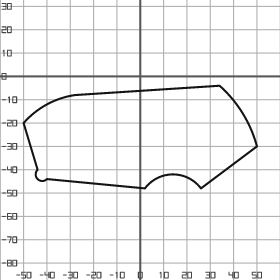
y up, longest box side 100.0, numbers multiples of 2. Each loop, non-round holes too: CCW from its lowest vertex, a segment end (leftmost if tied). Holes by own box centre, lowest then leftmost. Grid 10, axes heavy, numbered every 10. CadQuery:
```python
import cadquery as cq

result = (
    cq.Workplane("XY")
    .moveTo(2.0, -48.0)
    .threePointArc((14.0, -42.0), (26.0, -48.0))
    .lineTo(50.0, -30.0)
    .threePointArc((44.0, -16.0), (34.0, -4.0))
    .lineTo(-28.0, -8.0)
    .threePointArc((-40.0, -12.0), (-50.0, -20.0))
    .lineTo(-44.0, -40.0)
    .threePointArc((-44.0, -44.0), (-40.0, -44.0))
    .close()
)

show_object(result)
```